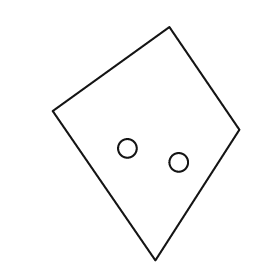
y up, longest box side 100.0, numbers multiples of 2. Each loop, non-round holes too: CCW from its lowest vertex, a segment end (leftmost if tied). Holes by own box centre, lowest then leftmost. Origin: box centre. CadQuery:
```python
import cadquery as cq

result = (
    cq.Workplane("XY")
    .moveTo(4.0, -50.0)
    .lineTo(40.0, 6.0)
    .lineTo(10.0, 50.0)
    .lineTo(-40.0, 14.0)
    .close()
    .moveTo(14.0, -8.0)
    .circle(4.0)
    .moveTo(-8.0, -2.0)
    .circle(4.0)
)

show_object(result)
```